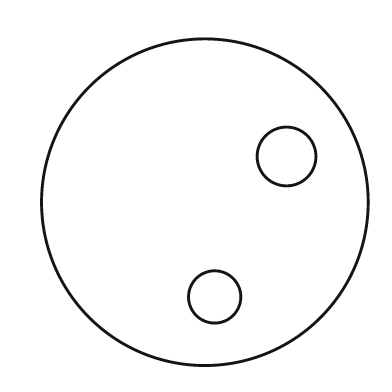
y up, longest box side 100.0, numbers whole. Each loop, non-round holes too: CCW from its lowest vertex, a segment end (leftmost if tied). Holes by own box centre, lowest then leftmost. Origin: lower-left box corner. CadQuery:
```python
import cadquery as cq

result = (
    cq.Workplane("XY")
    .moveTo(50.0, 50.0)
    .circle(50.0)
    .moveTo(53.0, 21.0)
    .circle(8.0)
    .moveTo(75.0, 64.0)
    .circle(9.0)
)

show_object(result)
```